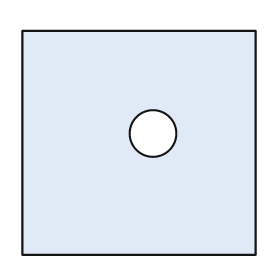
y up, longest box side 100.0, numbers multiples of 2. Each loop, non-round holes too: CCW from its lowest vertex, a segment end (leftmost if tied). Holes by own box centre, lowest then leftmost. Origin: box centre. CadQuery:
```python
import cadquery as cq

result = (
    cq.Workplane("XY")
    .moveTo(-50.0, -48.0)
    .lineTo(50.0, -48.0)
    .lineTo(50.0, 48.0)
    .lineTo(-50.0, 48.0)
    .close()
    .moveTo(6.0, 4.0)
    .circle(10.0)
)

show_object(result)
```